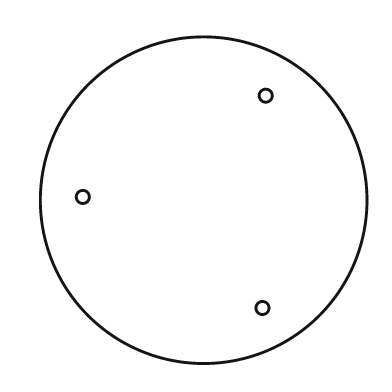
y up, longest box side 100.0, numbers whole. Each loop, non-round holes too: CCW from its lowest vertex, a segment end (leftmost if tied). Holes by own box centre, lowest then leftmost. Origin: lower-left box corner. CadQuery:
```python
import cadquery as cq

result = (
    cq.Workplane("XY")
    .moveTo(50.0, 50.0)
    .circle(50.0)
    .moveTo(68.0, 17.0)
    .circle(2.0)
    .moveTo(13.0, 51.0)
    .circle(2.0)
    .moveTo(69.0, 82.0)
    .circle(2.0)
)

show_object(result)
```